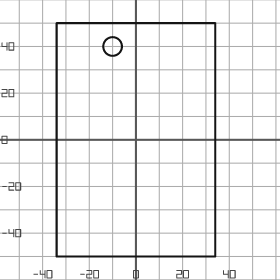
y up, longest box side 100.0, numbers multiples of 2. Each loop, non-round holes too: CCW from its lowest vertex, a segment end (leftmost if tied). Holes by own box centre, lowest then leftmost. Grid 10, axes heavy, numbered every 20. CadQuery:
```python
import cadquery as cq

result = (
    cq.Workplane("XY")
    .moveTo(-34.0, -50.0)
    .lineTo(34.0, -50.0)
    .lineTo(34.0, 50.0)
    .lineTo(-34.0, 50.0)
    .close()
    .moveTo(-10.0, 40.0)
    .circle(4.0)
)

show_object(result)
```